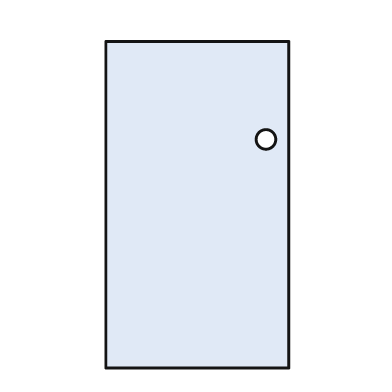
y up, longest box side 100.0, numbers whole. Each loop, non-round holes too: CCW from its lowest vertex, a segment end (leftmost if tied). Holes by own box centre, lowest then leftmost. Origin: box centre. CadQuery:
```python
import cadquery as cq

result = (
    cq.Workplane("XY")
    .moveTo(-28.0, -50.0)
    .lineTo(28.0, -50.0)
    .lineTo(28.0, 50.0)
    .lineTo(-28.0, 50.0)
    .close()
    .moveTo(21.0, 20.0)
    .circle(3.0)
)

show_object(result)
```